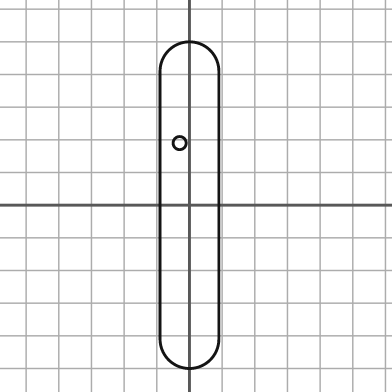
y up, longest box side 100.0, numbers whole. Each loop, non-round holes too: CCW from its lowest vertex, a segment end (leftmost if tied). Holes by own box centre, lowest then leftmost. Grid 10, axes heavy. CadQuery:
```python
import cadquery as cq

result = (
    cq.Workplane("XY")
    .moveTo(-9.0, -41.0)
    .threePointArc((0.0, -50.0), (9.0, -41.0))
    .lineTo(9.0, 41.0)
    .threePointArc((0.0, 50.0), (-9.0, 41.0))
    .close()
    .moveTo(-3.0, 19.0)
    .circle(2.0)
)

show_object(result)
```